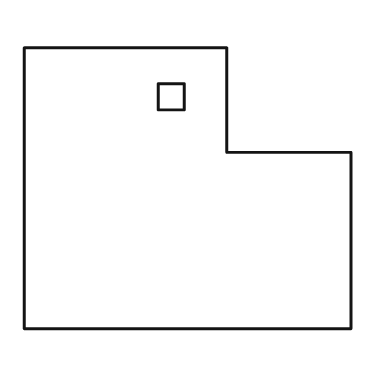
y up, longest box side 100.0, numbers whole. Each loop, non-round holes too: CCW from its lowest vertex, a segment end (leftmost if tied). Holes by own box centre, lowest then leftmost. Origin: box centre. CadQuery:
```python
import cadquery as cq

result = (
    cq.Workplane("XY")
    .moveTo(-50.0, -43.0)
    .lineTo(50.0, -43.0)
    .lineTo(50.0, 11.0)
    .lineTo(12.0, 11.0)
    .lineTo(12.0, 43.0)
    .lineTo(-50.0, 43.0)
    .close()
    .moveTo(-9.0, 24.0)
    .lineTo(-1.0, 24.0)
    .lineTo(-1.0, 32.0)
    .lineTo(-9.0, 32.0)
    .close()
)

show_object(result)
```